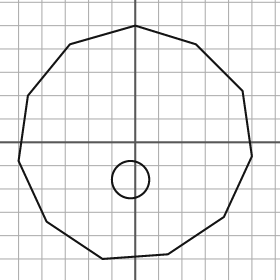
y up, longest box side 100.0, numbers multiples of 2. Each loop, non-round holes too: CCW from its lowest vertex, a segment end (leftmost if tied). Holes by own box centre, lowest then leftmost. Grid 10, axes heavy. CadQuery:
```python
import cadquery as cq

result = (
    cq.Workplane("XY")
    .moveTo(-14.0, -50.0)
    .lineTo(14.0, -48.0)
    .lineTo(38.0, -32.0)
    .lineTo(50.0, -6.0)
    .lineTo(46.0, 22.0)
    .lineTo(26.0, 42.0)
    .lineTo(0.0, 50.0)
    .lineTo(-28.0, 42.0)
    .lineTo(-46.0, 20.0)
    .lineTo(-50.0, -8.0)
    .lineTo(-38.0, -34.0)
    .close()
    .moveTo(-2.0, -16.0)
    .circle(8.0)
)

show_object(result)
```